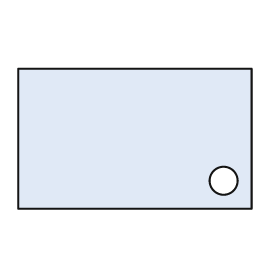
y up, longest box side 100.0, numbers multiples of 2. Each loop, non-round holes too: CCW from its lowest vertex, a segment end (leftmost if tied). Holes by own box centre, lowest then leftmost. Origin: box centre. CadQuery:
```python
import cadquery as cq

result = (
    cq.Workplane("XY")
    .moveTo(-50.0, -30.0)
    .lineTo(50.0, -30.0)
    .lineTo(50.0, 30.0)
    .lineTo(-50.0, 30.0)
    .close()
    .moveTo(38.0, -18.0)
    .circle(6.0)
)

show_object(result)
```